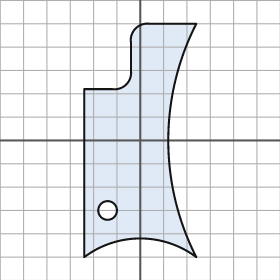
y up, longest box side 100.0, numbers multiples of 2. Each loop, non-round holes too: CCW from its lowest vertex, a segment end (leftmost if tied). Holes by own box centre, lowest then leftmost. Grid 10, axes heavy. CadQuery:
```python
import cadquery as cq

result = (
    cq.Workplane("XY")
    .moveTo(-24.0, -50.0)
    .threePointArc((0.0, -42.0), (24.0, -50.0))
    .threePointArc((12.0, 0.0), (24.0, 50.0))
    .lineTo(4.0, 50.0)
    .threePointArc((-2.0, 48.0), (-4.0, 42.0))
    .lineTo(-4.0, 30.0)
    .threePointArc((-6.0, 24.0), (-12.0, 22.0))
    .lineTo(-24.0, 22.0)
    .close()
    .moveTo(-14.0, -30.0)
    .circle(4.0)
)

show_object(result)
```